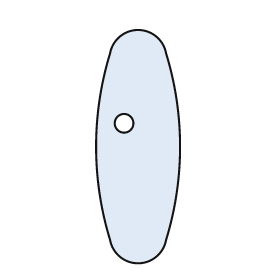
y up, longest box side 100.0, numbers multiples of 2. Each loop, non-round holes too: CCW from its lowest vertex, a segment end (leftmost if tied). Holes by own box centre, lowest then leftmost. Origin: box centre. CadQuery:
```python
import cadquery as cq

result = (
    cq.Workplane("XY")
    .moveTo(-12.0, -40.0)
    .threePointArc((0.0, -50.0), (12.0, -40.0))
    .threePointArc((18.0, 0.0), (12.0, 40.0))
    .threePointArc((0.0, 50.0), (-12.0, 40.0))
    .threePointArc((-18.0, 0.0), (-12.0, -40.0))
    .close()
    .moveTo(-6.0, 10.0)
    .circle(4.0)
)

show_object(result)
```